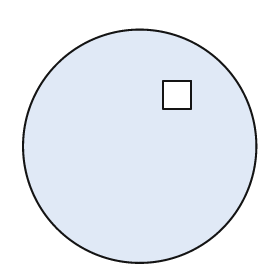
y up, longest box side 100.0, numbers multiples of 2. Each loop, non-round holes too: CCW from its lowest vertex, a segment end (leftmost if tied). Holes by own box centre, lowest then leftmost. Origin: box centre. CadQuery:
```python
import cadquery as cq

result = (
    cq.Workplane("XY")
    .moveTo(0.0, 0.0)
    .circle(50.0)
    .moveTo(10.0, 16.0)
    .lineTo(22.0, 16.0)
    .lineTo(22.0, 28.0)
    .lineTo(10.0, 28.0)
    .close()
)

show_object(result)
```